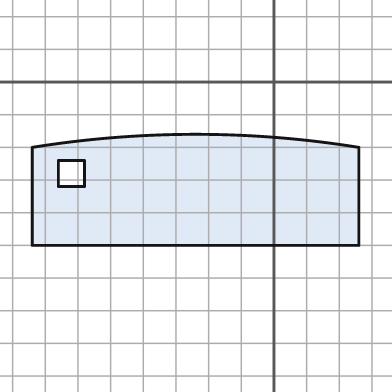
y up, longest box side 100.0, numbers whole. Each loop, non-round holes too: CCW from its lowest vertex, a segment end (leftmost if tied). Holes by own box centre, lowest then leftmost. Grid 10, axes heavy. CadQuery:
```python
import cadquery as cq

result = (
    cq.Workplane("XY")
    .moveTo(-74.0, -50.0)
    .lineTo(26.0, -50.0)
    .lineTo(26.0, -20.0)
    .threePointArc((-24.0, -16.0), (-74.0, -20.0))
    .close()
    .moveTo(-66.0, -32.0)
    .lineTo(-58.0, -32.0)
    .lineTo(-58.0, -24.0)
    .lineTo(-66.0, -24.0)
    .close()
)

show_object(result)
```